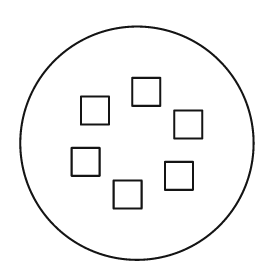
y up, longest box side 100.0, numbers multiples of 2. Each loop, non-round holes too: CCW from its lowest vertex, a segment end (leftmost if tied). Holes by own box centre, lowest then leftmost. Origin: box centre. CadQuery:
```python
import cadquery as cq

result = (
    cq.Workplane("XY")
    .moveTo(0.0, 0.0)
    .circle(50.0)
    .moveTo(-10.0, -28.0)
    .lineTo(2.0, -28.0)
    .lineTo(2.0, -16.0)
    .lineTo(-10.0, -16.0)
    .close()
    .moveTo(12.0, -20.0)
    .lineTo(24.0, -20.0)
    .lineTo(24.0, -8.0)
    .lineTo(12.0, -8.0)
    .close()
    .moveTo(-28.0, -14.0)
    .lineTo(-16.0, -14.0)
    .lineTo(-16.0, -2.0)
    .lineTo(-28.0, -2.0)
    .close()
    .moveTo(16.0, 2.0)
    .lineTo(28.0, 2.0)
    .lineTo(28.0, 14.0)
    .lineTo(16.0, 14.0)
    .close()
    .moveTo(-24.0, 8.0)
    .lineTo(-12.0, 8.0)
    .lineTo(-12.0, 20.0)
    .lineTo(-24.0, 20.0)
    .close()
    .moveTo(-2.0, 16.0)
    .lineTo(10.0, 16.0)
    .lineTo(10.0, 28.0)
    .lineTo(-2.0, 28.0)
    .close()
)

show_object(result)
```